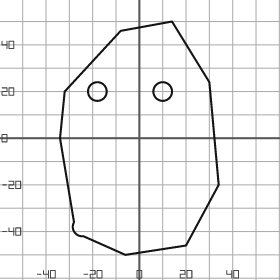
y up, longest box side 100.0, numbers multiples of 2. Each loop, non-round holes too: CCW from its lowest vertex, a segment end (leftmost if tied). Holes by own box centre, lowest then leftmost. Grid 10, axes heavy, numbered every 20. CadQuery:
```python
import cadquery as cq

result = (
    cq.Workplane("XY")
    .moveTo(-6.0, -50.0)
    .lineTo(20.0, -46.0)
    .lineTo(34.0, -20.0)
    .lineTo(30.0, 24.0)
    .lineTo(14.0, 50.0)
    .lineTo(-8.0, 46.0)
    .lineTo(-32.0, 20.0)
    .lineTo(-34.0, 0.0)
    .lineTo(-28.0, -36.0)
    .threePointArc((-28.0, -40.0), (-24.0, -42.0))
    .close()
    .moveTo(-18.0, 20.0)
    .circle(4.0)
    .moveTo(10.0, 20.0)
    .circle(4.0)
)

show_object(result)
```